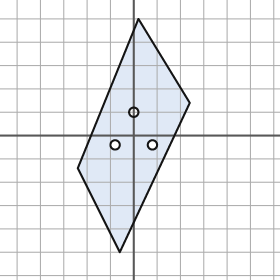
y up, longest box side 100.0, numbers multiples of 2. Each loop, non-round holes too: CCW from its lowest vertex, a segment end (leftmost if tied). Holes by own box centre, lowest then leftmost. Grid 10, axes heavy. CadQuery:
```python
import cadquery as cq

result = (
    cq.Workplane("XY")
    .moveTo(-6.0, -50.0)
    .lineTo(24.0, 14.0)
    .lineTo(2.0, 50.0)
    .lineTo(-24.0, -14.0)
    .close()
    .moveTo(-8.0, -4.0)
    .circle(2.0)
    .moveTo(8.0, -4.0)
    .circle(2.0)
    .moveTo(0.0, 10.0)
    .circle(2.0)
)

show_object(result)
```